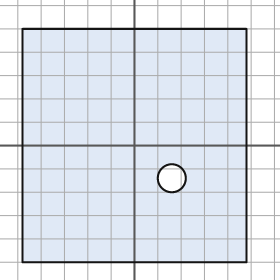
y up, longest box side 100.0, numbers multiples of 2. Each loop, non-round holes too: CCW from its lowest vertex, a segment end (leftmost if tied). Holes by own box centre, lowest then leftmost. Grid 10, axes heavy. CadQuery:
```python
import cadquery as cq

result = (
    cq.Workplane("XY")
    .moveTo(-48.0, -50.0)
    .lineTo(48.0, -50.0)
    .lineTo(48.0, 50.0)
    .lineTo(-48.0, 50.0)
    .close()
    .moveTo(16.0, -14.0)
    .circle(6.0)
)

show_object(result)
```